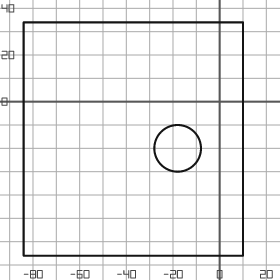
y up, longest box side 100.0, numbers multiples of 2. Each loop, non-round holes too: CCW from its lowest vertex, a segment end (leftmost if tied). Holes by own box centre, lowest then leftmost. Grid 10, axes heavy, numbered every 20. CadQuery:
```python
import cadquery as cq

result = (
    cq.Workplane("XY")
    .moveTo(-84.0, -66.0)
    .lineTo(10.0, -66.0)
    .lineTo(10.0, 34.0)
    .lineTo(-84.0, 34.0)
    .close()
    .moveTo(-18.0, -20.0)
    .circle(10.0)
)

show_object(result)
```